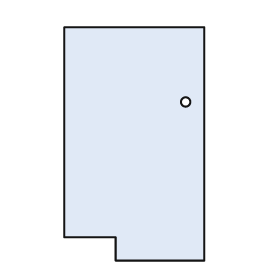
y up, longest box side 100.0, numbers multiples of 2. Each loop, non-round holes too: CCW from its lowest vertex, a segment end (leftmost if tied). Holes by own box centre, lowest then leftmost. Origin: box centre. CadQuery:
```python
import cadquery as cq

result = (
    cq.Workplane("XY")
    .moveTo(-8.0, -50.0)
    .lineTo(30.0, -50.0)
    .lineTo(30.0, 50.0)
    .lineTo(-30.0, 50.0)
    .lineTo(-30.0, -40.0)
    .lineTo(-8.0, -40.0)
    .close()
    .moveTo(22.0, 18.0)
    .circle(2.0)
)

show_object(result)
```